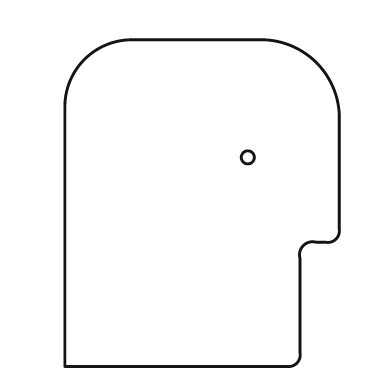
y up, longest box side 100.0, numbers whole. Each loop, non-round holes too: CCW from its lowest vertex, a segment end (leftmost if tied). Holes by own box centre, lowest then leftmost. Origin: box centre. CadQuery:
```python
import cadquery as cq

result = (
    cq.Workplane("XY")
    .moveTo(-42.0, -50.0)
    .lineTo(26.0, -50.0)
    .threePointArc((29.0, -49.0), (30.0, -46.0))
    .lineTo(30.0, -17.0)
    .threePointArc((31.0, -13.0), (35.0, -12.0))
    .lineTo(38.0, -12.0)
    .threePointArc((41.0, -11.0), (42.0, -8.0))
    .lineTo(42.0, 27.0)
    .threePointArc((35.0, 43.0), (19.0, 50.0))
    .lineTo(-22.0, 50.0)
    .threePointArc((-36.0, 44.0), (-42.0, 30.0))
    .close()
    .moveTo(14.0, 14.0)
    .circle(2.0)
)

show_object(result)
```